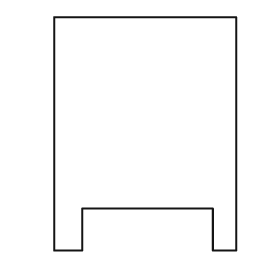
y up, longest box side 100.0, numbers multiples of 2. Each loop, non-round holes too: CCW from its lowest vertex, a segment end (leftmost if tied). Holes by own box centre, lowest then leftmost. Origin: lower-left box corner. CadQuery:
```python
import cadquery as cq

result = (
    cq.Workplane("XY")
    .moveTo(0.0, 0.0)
    .lineTo(12.0, 0.0)
    .lineTo(12.0, 18.0)
    .lineTo(68.0, 18.0)
    .lineTo(68.0, 0.0)
    .lineTo(78.0, 0.0)
    .lineTo(78.0, 100.0)
    .lineTo(0.0, 100.0)
    .close()
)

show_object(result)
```